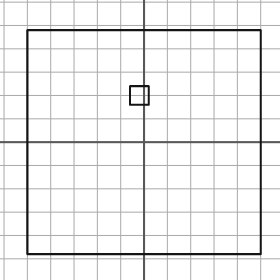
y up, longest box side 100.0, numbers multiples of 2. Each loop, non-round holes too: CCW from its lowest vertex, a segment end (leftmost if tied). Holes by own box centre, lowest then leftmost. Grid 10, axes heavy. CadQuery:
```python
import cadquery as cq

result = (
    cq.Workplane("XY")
    .moveTo(-50.0, -48.0)
    .lineTo(50.0, -48.0)
    .lineTo(50.0, 48.0)
    .lineTo(-50.0, 48.0)
    .close()
    .moveTo(-6.0, 16.0)
    .lineTo(2.0, 16.0)
    .lineTo(2.0, 24.0)
    .lineTo(-6.0, 24.0)
    .close()
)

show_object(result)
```